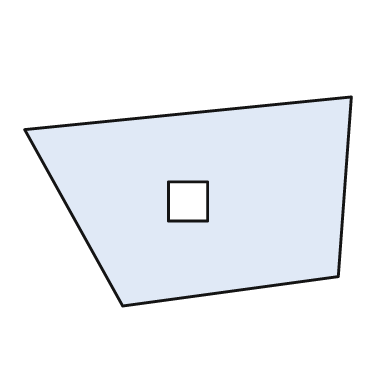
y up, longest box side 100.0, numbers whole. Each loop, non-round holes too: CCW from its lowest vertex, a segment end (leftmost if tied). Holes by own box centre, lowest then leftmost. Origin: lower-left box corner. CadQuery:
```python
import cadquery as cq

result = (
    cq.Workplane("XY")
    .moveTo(30.0, 0.0)
    .lineTo(96.0, 9.0)
    .lineTo(100.0, 64.0)
    .lineTo(0.0, 54.0)
    .close()
    .moveTo(44.0, 26.0)
    .lineTo(56.0, 26.0)
    .lineTo(56.0, 38.0)
    .lineTo(44.0, 38.0)
    .close()
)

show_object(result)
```